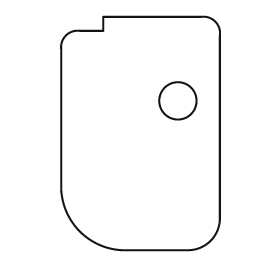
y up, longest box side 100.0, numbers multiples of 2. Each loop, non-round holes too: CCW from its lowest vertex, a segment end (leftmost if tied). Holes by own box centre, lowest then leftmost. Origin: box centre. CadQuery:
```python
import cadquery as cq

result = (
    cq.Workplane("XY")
    .moveTo(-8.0, -50.0)
    .lineTo(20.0, -50.0)
    .threePointArc((30.0, -46.0), (34.0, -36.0))
    .lineTo(34.0, 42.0)
    .threePointArc((32.0, 48.0), (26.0, 50.0))
    .lineTo(-16.0, 50.0)
    .lineTo(-16.0, 44.0)
    .lineTo(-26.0, 44.0)
    .threePointArc((-32.0, 42.0), (-34.0, 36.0))
    .lineTo(-34.0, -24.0)
    .threePointArc((-26.0, -42.0), (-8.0, -50.0))
    .close()
    .moveTo(16.0, 14.0)
    .circle(8.0)
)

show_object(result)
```